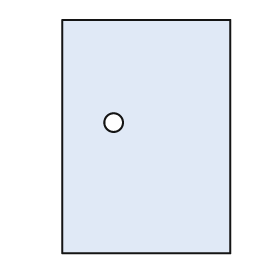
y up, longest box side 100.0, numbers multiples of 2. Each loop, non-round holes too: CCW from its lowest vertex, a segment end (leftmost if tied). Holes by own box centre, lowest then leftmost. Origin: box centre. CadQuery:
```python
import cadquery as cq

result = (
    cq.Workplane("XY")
    .moveTo(-36.0, -50.0)
    .lineTo(36.0, -50.0)
    .lineTo(36.0, 50.0)
    .lineTo(-36.0, 50.0)
    .close()
    .moveTo(-14.0, 6.0)
    .circle(4.0)
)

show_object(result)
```